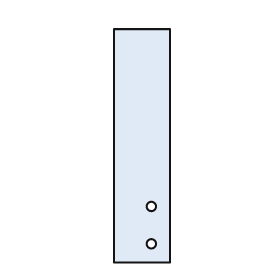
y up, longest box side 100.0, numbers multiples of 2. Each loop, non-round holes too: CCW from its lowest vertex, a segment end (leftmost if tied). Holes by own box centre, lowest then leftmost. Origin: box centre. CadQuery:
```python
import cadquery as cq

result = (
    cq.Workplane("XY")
    .moveTo(-12.0, -50.0)
    .lineTo(12.0, -50.0)
    .lineTo(12.0, 50.0)
    .lineTo(-12.0, 50.0)
    .close()
    .moveTo(4.0, -42.0)
    .circle(2.0)
    .moveTo(4.0, -26.0)
    .circle(2.0)
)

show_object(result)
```